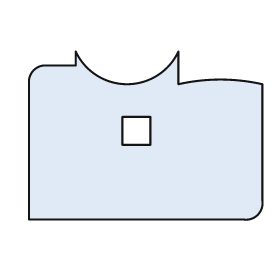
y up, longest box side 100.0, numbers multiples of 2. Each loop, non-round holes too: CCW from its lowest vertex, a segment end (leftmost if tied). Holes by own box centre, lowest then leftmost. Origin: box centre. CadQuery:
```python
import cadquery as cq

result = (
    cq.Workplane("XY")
    .moveTo(-50.0, -36.0)
    .lineTo(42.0, -36.0)
    .threePointArc((48.0, -34.0), (50.0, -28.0))
    .lineTo(50.0, 22.0)
    .threePointArc((32.0, 24.0), (14.0, 22.0))
    .lineTo(14.0, 36.0)
    .threePointArc((-8.0, 22.0), (-30.0, 36.0))
    .lineTo(-30.0, 30.0)
    .lineTo(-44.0, 30.0)
    .threePointArc((-48.0, 28.0), (-50.0, 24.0))
    .close()
    .moveTo(-10.0, -4.0)
    .lineTo(2.0, -4.0)
    .lineTo(2.0, 8.0)
    .lineTo(-10.0, 8.0)
    .close()
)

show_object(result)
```